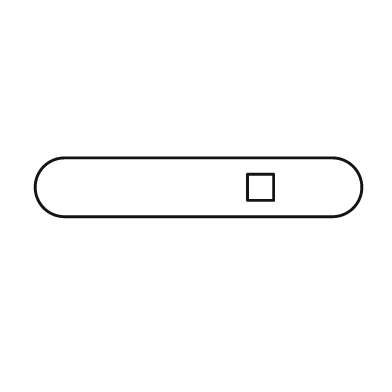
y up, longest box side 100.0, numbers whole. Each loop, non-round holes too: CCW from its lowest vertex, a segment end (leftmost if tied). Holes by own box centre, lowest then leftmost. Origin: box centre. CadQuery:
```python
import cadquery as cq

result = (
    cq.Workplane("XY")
    .moveTo(-41.0, -9.0)
    .lineTo(41.0, -9.0)
    .threePointArc((50.0, 0.0), (41.0, 9.0))
    .lineTo(-41.0, 9.0)
    .threePointArc((-50.0, 0.0), (-41.0, -9.0))
    .close()
    .moveTo(15.0, -4.0)
    .lineTo(23.0, -4.0)
    .lineTo(23.0, 4.0)
    .lineTo(15.0, 4.0)
    .close()
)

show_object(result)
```